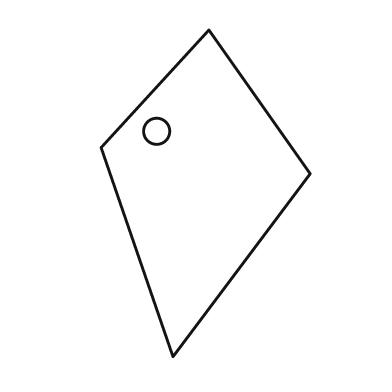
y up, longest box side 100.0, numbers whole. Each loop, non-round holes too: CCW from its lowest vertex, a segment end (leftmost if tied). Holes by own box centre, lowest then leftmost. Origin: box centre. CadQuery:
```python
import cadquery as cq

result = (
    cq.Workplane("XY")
    .moveTo(-10.0, -50.0)
    .lineTo(32.0, 6.0)
    .lineTo(1.0, 50.0)
    .lineTo(-32.0, 14.0)
    .close()
    .moveTo(-15.0, 19.0)
    .circle(4.0)
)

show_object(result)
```